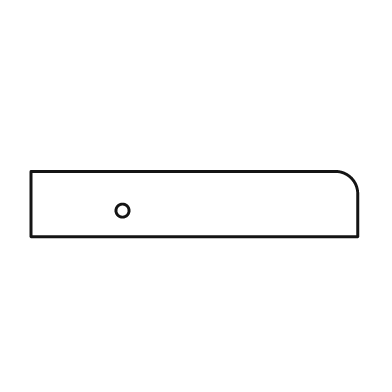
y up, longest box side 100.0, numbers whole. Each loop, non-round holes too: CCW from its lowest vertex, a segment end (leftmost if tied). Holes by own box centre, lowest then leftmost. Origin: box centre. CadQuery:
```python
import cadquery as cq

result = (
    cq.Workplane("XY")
    .moveTo(-50.0, -10.0)
    .lineTo(50.0, -10.0)
    .lineTo(50.0, 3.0)
    .threePointArc((48.0, 8.0), (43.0, 10.0))
    .lineTo(-50.0, 10.0)
    .close()
    .moveTo(-22.0, -2.0)
    .circle(2.0)
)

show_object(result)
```